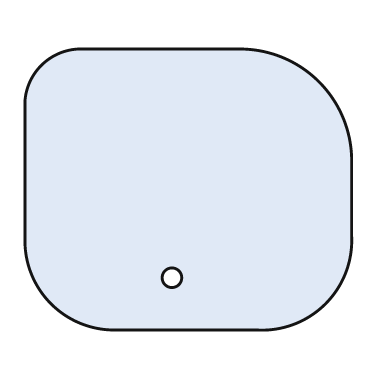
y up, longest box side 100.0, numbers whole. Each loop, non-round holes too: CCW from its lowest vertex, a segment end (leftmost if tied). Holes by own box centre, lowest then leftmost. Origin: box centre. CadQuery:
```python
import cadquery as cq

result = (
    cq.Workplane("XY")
    .moveTo(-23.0, -43.0)
    .lineTo(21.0, -43.0)
    .threePointArc((42.0, -35.0), (50.0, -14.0))
    .lineTo(50.0, 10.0)
    .threePointArc((40.0, 33.0), (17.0, 43.0))
    .lineTo(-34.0, 43.0)
    .threePointArc((-45.0, 38.0), (-50.0, 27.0))
    .lineTo(-50.0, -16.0)
    .threePointArc((-42.0, -35.0), (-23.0, -43.0))
    .close()
    .moveTo(-5.0, -27.0)
    .circle(3.0)
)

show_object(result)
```